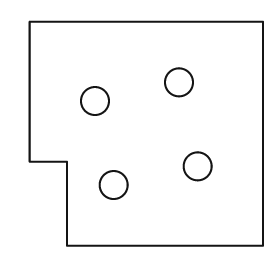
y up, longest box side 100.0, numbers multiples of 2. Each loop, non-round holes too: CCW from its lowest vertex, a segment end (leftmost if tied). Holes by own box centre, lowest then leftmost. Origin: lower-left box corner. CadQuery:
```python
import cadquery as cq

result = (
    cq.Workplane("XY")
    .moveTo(16.0, 0.0)
    .lineTo(100.0, 0.0)
    .lineTo(100.0, 96.0)
    .lineTo(0.0, 96.0)
    .lineTo(0.0, 36.0)
    .lineTo(16.0, 36.0)
    .close()
    .moveTo(36.0, 26.0)
    .circle(6.0)
    .moveTo(72.0, 34.0)
    .circle(6.0)
    .moveTo(28.0, 62.0)
    .circle(6.0)
    .moveTo(64.0, 70.0)
    .circle(6.0)
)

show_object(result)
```